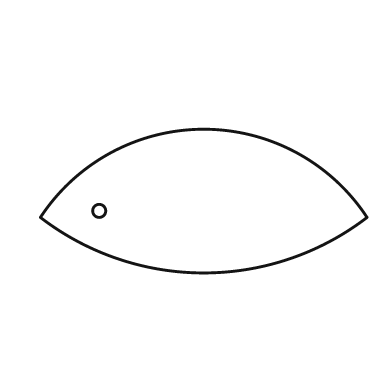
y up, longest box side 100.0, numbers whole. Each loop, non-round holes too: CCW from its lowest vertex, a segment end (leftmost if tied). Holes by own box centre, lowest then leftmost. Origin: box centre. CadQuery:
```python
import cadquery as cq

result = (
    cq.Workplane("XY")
    .moveTo(-50.0, -5.0)
    .threePointArc((0.0, -22.0), (50.0, -5.0))
    .threePointArc((0.0, 22.0), (-50.0, -5.0))
    .close()
    .moveTo(-32.0, -3.0)
    .circle(2.0)
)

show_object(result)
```